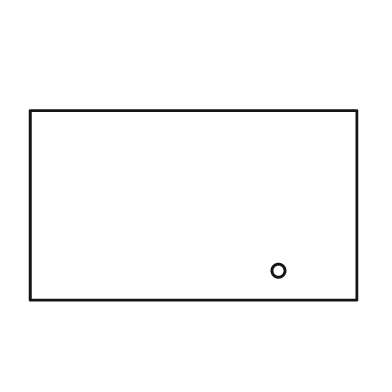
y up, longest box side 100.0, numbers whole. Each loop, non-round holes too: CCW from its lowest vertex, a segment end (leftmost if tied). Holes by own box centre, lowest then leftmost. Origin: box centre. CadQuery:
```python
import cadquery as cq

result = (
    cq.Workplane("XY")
    .moveTo(-50.0, -29.0)
    .lineTo(50.0, -29.0)
    .lineTo(50.0, 29.0)
    .lineTo(-50.0, 29.0)
    .close()
    .moveTo(26.0, -20.0)
    .circle(2.0)
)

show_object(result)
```